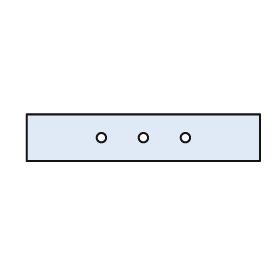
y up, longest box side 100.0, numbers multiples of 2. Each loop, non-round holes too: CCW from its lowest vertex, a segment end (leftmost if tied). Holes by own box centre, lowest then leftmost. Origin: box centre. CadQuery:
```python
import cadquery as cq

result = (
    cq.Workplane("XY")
    .moveTo(-50.0, -10.0)
    .lineTo(50.0, -10.0)
    .lineTo(50.0, 10.0)
    .lineTo(-50.0, 10.0)
    .close()
    .moveTo(-18.0, 0.0)
    .circle(2.0)
    .moveTo(0.0, 0.0)
    .circle(2.0)
    .moveTo(18.0, 0.0)
    .circle(2.0)
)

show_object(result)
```